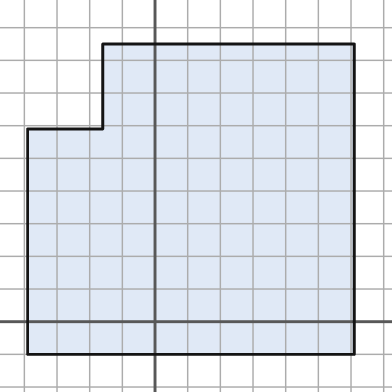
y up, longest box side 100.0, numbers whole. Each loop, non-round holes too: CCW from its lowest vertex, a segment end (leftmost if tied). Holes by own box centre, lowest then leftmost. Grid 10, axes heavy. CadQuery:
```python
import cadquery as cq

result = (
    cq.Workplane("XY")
    .moveTo(-39.0, -10.0)
    .lineTo(61.0, -10.0)
    .lineTo(61.0, 85.0)
    .lineTo(-16.0, 85.0)
    .lineTo(-16.0, 59.0)
    .lineTo(-39.0, 59.0)
    .close()
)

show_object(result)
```